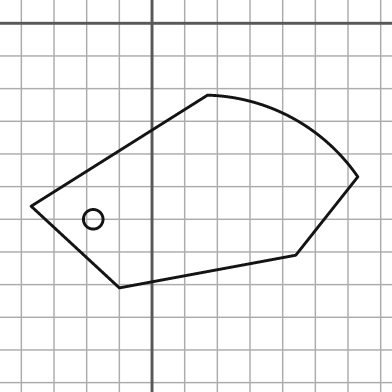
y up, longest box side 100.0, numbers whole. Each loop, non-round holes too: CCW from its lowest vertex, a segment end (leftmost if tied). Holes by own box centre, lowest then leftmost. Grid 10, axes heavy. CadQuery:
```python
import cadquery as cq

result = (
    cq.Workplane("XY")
    .moveTo(-10.0, -81.0)
    .lineTo(44.0, -71.0)
    .lineTo(63.0, -47.0)
    .threePointArc((43.0, -29.0), (17.0, -22.0))
    .lineTo(-37.0, -56.0)
    .close()
    .moveTo(-18.0, -60.0)
    .circle(3.0)
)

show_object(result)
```